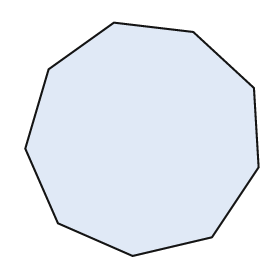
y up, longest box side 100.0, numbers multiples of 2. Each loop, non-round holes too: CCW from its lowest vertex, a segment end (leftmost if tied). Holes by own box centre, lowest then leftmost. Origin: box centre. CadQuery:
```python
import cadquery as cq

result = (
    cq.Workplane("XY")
    .moveTo(-4.0, -50.0)
    .lineTo(30.0, -42.0)
    .lineTo(50.0, -12.0)
    .lineTo(48.0, 22.0)
    .lineTo(22.0, 46.0)
    .lineTo(-12.0, 50.0)
    .lineTo(-40.0, 30.0)
    .lineTo(-50.0, -4.0)
    .lineTo(-36.0, -36.0)
    .close()
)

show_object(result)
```